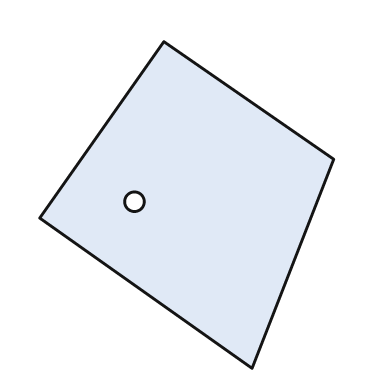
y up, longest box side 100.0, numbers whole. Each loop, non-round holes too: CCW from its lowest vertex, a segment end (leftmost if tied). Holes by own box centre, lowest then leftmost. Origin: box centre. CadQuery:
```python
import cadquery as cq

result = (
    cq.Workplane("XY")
    .moveTo(20.0, -50.0)
    .lineTo(45.0, 14.0)
    .lineTo(-7.0, 50.0)
    .lineTo(-45.0, -4.0)
    .close()
    .moveTo(-16.0, 1.0)
    .circle(3.0)
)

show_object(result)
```